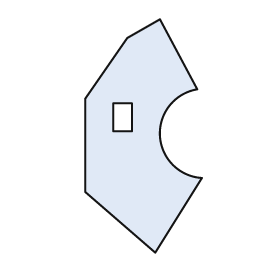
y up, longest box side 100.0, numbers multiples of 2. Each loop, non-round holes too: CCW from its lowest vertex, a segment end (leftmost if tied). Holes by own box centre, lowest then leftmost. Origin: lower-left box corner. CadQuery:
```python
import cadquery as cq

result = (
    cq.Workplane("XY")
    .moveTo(30.0, 0.0)
    .lineTo(50.0, 32.0)
    .threePointArc((32.0, 50.0), (48.0, 70.0))
    .lineTo(32.0, 100.0)
    .lineTo(18.0, 92.0)
    .lineTo(0.0, 66.0)
    .lineTo(0.0, 26.0)
    .close()
    .moveTo(12.0, 52.0)
    .lineTo(20.0, 52.0)
    .lineTo(20.0, 64.0)
    .lineTo(12.0, 64.0)
    .close()
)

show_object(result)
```